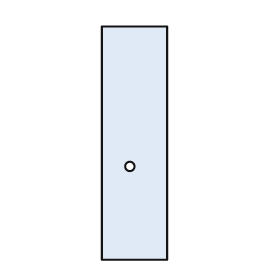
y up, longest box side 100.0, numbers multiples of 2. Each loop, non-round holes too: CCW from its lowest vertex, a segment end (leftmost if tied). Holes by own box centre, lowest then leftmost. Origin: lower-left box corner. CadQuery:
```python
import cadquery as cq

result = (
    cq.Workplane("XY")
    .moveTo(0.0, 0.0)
    .lineTo(28.0, 0.0)
    .lineTo(28.0, 100.0)
    .lineTo(0.0, 100.0)
    .close()
    .moveTo(12.0, 40.0)
    .circle(2.0)
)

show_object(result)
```